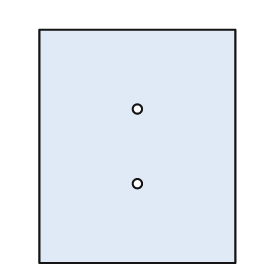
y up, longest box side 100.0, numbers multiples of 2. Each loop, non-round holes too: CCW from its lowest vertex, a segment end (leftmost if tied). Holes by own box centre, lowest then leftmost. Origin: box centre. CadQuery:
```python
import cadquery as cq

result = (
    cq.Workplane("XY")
    .moveTo(-42.0, -50.0)
    .lineTo(42.0, -50.0)
    .lineTo(42.0, 50.0)
    .lineTo(-42.0, 50.0)
    .close()
    .moveTo(0.0, -16.0)
    .circle(2.0)
    .moveTo(0.0, 16.0)
    .circle(2.0)
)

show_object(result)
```